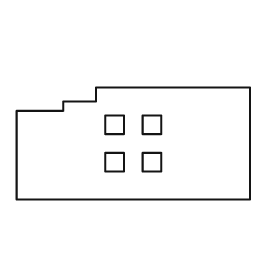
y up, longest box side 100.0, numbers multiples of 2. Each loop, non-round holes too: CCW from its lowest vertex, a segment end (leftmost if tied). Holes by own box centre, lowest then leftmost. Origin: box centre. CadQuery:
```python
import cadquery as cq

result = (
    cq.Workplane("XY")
    .moveTo(-50.0, -24.0)
    .lineTo(50.0, -24.0)
    .lineTo(50.0, 24.0)
    .lineTo(-16.0, 24.0)
    .lineTo(-16.0, 18.0)
    .lineTo(-30.0, 18.0)
    .lineTo(-30.0, 14.0)
    .lineTo(-50.0, 14.0)
    .close()
    .moveTo(-12.0, -12.0)
    .lineTo(-4.0, -12.0)
    .lineTo(-4.0, -4.0)
    .lineTo(-12.0, -4.0)
    .close()
    .moveTo(4.0, -12.0)
    .lineTo(12.0, -12.0)
    .lineTo(12.0, -4.0)
    .lineTo(4.0, -4.0)
    .close()
    .moveTo(-12.0, 4.0)
    .lineTo(-4.0, 4.0)
    .lineTo(-4.0, 12.0)
    .lineTo(-12.0, 12.0)
    .close()
    .moveTo(4.0, 4.0)
    .lineTo(12.0, 4.0)
    .lineTo(12.0, 12.0)
    .lineTo(4.0, 12.0)
    .close()
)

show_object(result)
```